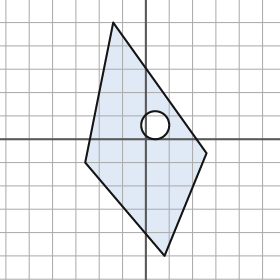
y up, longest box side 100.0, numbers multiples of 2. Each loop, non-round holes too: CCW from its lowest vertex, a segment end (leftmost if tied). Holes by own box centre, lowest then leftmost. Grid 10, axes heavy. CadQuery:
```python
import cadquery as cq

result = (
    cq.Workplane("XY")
    .moveTo(8.0, -50.0)
    .lineTo(26.0, -6.0)
    .lineTo(-14.0, 50.0)
    .lineTo(-26.0, -10.0)
    .close()
    .moveTo(4.0, 6.0)
    .circle(6.0)
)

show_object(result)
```